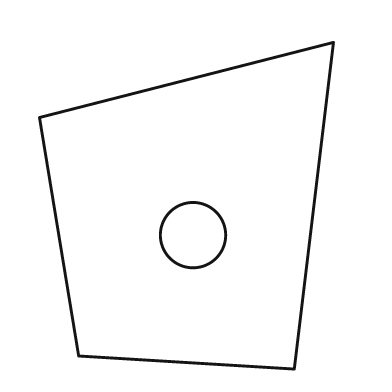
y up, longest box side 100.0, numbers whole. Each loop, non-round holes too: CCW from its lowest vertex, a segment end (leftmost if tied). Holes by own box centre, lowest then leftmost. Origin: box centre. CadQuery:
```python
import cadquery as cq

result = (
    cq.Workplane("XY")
    .moveTo(33.0, -50.0)
    .lineTo(45.0, 50.0)
    .lineTo(-45.0, 27.0)
    .lineTo(-33.0, -46.0)
    .close()
    .moveTo(2.0, -9.0)
    .circle(10.0)
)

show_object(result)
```